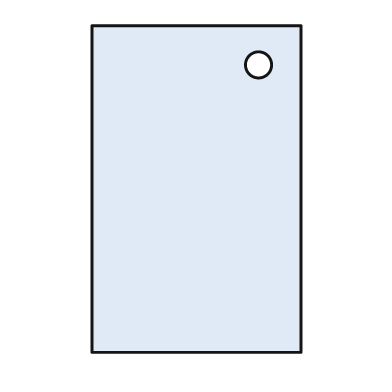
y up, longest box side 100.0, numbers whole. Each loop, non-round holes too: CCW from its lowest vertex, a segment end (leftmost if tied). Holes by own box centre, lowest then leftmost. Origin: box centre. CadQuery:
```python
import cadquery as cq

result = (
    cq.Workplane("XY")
    .moveTo(-32.0, -50.0)
    .lineTo(32.0, -50.0)
    .lineTo(32.0, 50.0)
    .lineTo(-32.0, 50.0)
    .close()
    .moveTo(19.0, 38.0)
    .circle(4.0)
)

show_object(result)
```